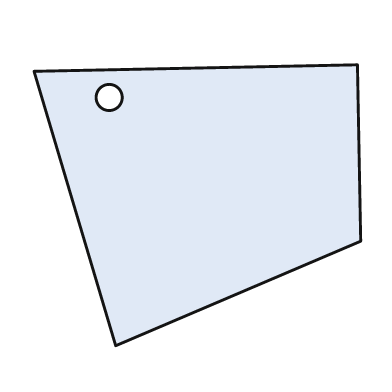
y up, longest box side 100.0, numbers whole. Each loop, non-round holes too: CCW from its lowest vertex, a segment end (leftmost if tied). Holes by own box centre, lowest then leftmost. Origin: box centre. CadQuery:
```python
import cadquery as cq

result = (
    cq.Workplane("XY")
    .moveTo(-25.0, -43.0)
    .lineTo(50.0, -11.0)
    .lineTo(49.0, 43.0)
    .lineTo(-50.0, 41.0)
    .close()
    .moveTo(-27.0, 33.0)
    .circle(4.0)
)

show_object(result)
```